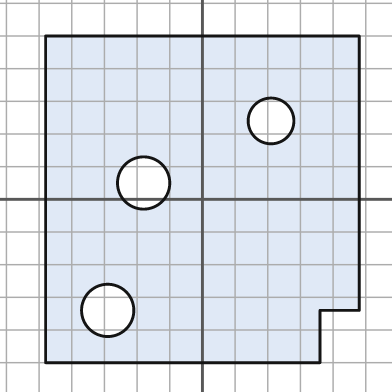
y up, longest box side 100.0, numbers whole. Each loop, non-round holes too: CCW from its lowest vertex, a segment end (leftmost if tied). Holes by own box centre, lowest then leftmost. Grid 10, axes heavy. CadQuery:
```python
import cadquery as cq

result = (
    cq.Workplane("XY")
    .moveTo(-48.0, -50.0)
    .lineTo(36.0, -50.0)
    .lineTo(36.0, -34.0)
    .lineTo(48.0, -34.0)
    .lineTo(48.0, 50.0)
    .lineTo(-48.0, 50.0)
    .close()
    .moveTo(-29.0, -34.0)
    .circle(8.0)
    .moveTo(-18.0, 5.0)
    .circle(8.0)
    .moveTo(21.0, 24.0)
    .circle(7.0)
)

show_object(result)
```